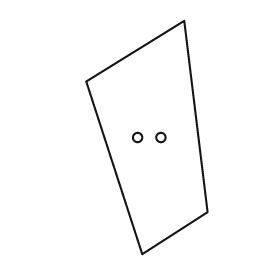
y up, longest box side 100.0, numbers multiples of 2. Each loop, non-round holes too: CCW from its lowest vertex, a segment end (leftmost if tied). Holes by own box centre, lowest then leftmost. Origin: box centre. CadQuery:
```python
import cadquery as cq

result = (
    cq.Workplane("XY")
    .moveTo(-2.0, -50.0)
    .lineTo(26.0, -32.0)
    .lineTo(16.0, 50.0)
    .lineTo(-26.0, 24.0)
    .close()
    .moveTo(-4.0, 0.0)
    .circle(2.0)
    .moveTo(6.0, 0.0)
    .circle(2.0)
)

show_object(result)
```